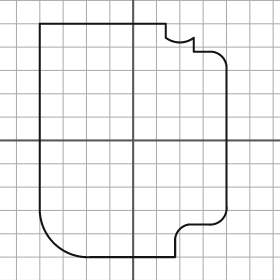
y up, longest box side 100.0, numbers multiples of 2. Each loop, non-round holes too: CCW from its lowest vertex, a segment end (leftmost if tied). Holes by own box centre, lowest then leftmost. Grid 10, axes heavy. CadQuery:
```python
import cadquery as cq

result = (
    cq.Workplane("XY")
    .moveTo(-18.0, -50.0)
    .lineTo(18.0, -50.0)
    .lineTo(18.0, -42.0)
    .threePointArc((20.0, -38.0), (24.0, -36.0))
    .lineTo(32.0, -36.0)
    .threePointArc((38.0, -34.0), (40.0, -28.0))
    .lineTo(40.0, 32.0)
    .threePointArc((38.0, 36.0), (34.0, 38.0))
    .lineTo(26.0, 38.0)
    .lineTo(26.0, 44.0)
    .threePointArc((20.0, 42.0), (14.0, 44.0))
    .lineTo(14.0, 50.0)
    .lineTo(-40.0, 50.0)
    .lineTo(-40.0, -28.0)
    .threePointArc((-34.0, -44.0), (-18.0, -50.0))
    .close()
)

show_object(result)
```